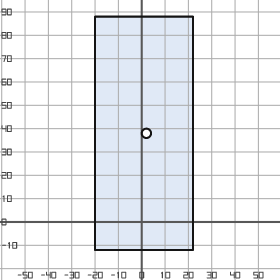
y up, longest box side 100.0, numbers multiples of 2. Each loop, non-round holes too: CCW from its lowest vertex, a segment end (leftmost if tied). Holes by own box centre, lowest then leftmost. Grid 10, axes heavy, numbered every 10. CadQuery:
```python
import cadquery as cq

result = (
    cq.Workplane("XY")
    .moveTo(-20.0, -12.0)
    .lineTo(22.0, -12.0)
    .lineTo(22.0, 88.0)
    .lineTo(-20.0, 88.0)
    .close()
    .moveTo(2.0, 38.0)
    .circle(2.0)
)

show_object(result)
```